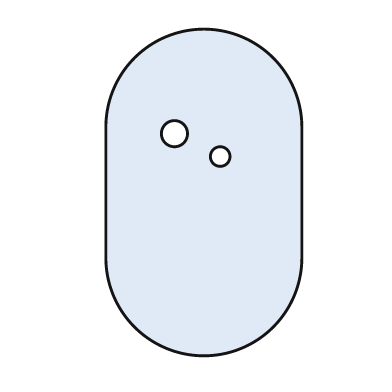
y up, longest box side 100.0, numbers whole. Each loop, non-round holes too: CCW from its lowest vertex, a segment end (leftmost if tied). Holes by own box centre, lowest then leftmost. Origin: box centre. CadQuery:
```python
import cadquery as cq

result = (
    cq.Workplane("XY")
    .moveTo(-30.0, -20.0)
    .threePointArc((0.0, -50.0), (30.0, -20.0))
    .lineTo(30.0, 20.0)
    .threePointArc((0.0, 50.0), (-30.0, 20.0))
    .close()
    .moveTo(5.0, 11.0)
    .circle(3.0)
    .moveTo(-9.0, 18.0)
    .circle(4.0)
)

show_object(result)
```